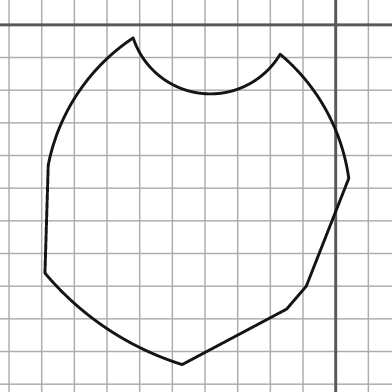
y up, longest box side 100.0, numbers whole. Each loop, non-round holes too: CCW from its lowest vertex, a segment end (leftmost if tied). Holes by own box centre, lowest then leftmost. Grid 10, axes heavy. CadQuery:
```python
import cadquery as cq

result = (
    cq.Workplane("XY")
    .moveTo(-47.0, -104.0)
    .lineTo(-15.0, -87.0)
    .lineTo(-9.0, -80.0)
    .lineTo(4.0, -47.0)
    .threePointArc((-3.0, -26.0), (-17.0, -9.0))
    .threePointArc((-41.0, -21.0), (-62.0, -4.0))
    .threePointArc((-79.0, -21.0), (-88.0, -43.0))
    .lineTo(-89.0, -76.0)
    .threePointArc((-70.0, -93.0), (-47.0, -104.0))
    .close()
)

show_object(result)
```